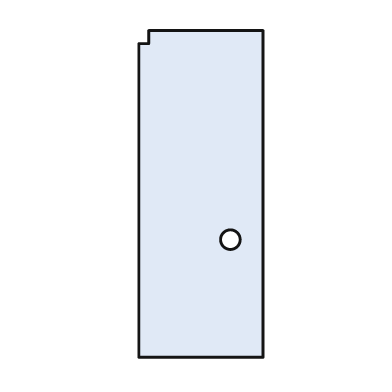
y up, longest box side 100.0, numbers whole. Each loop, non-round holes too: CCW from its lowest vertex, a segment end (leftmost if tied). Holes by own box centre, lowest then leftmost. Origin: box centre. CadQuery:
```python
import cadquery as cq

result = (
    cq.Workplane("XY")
    .moveTo(-19.0, -50.0)
    .lineTo(19.0, -50.0)
    .lineTo(19.0, 50.0)
    .lineTo(-16.0, 50.0)
    .lineTo(-16.0, 46.0)
    .lineTo(-19.0, 46.0)
    .close()
    .moveTo(9.0, -14.0)
    .circle(3.0)
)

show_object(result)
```